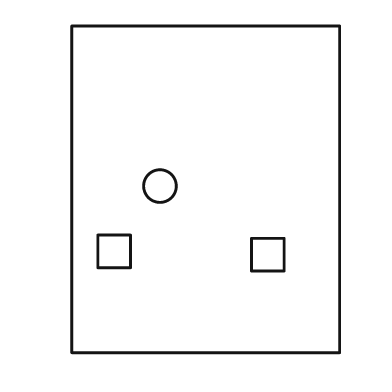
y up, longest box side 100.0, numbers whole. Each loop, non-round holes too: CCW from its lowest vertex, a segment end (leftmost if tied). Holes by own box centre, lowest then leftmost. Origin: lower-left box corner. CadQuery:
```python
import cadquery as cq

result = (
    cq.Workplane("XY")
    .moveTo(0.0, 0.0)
    .lineTo(82.0, 0.0)
    .lineTo(82.0, 100.0)
    .lineTo(0.0, 100.0)
    .close()
    .moveTo(55.0, 25.0)
    .lineTo(65.0, 25.0)
    .lineTo(65.0, 35.0)
    .lineTo(55.0, 35.0)
    .close()
    .moveTo(8.0, 26.0)
    .lineTo(18.0, 26.0)
    .lineTo(18.0, 36.0)
    .lineTo(8.0, 36.0)
    .close()
    .moveTo(27.0, 51.0)
    .circle(5.0)
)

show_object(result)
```